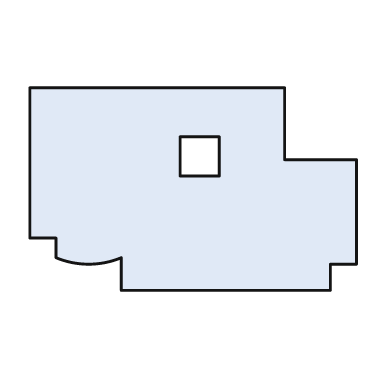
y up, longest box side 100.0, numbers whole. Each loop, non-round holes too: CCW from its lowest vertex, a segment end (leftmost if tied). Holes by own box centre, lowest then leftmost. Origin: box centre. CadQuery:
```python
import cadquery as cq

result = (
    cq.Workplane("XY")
    .moveTo(-22.0, -31.0)
    .lineTo(42.0, -31.0)
    .lineTo(42.0, -23.0)
    .lineTo(50.0, -23.0)
    .lineTo(50.0, 9.0)
    .lineTo(28.0, 9.0)
    .lineTo(28.0, 31.0)
    .lineTo(-50.0, 31.0)
    .lineTo(-50.0, -15.0)
    .lineTo(-42.0, -15.0)
    .lineTo(-42.0, -21.0)
    .threePointArc((-32.0, -23.0), (-22.0, -21.0))
    .close()
    .moveTo(-4.0, 4.0)
    .lineTo(8.0, 4.0)
    .lineTo(8.0, 16.0)
    .lineTo(-4.0, 16.0)
    .close()
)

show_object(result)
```